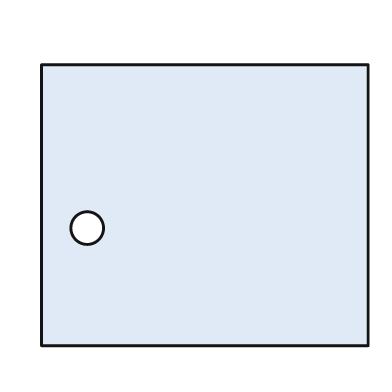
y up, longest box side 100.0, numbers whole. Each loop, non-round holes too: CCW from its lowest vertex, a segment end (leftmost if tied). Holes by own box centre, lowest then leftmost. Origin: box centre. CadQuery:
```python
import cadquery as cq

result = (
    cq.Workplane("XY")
    .moveTo(-50.0, -43.0)
    .lineTo(50.0, -43.0)
    .lineTo(50.0, 43.0)
    .lineTo(-50.0, 43.0)
    .close()
    .moveTo(-36.0, -7.0)
    .circle(5.0)
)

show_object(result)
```